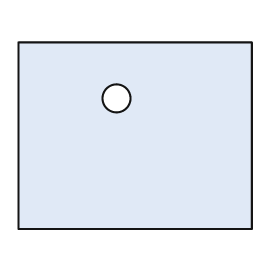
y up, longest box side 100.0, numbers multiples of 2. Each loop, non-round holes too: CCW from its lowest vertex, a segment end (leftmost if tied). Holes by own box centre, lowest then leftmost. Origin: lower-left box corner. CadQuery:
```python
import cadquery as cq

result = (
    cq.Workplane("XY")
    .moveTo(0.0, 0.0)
    .lineTo(100.0, 0.0)
    .lineTo(100.0, 80.0)
    .lineTo(0.0, 80.0)
    .close()
    .moveTo(42.0, 56.0)
    .circle(6.0)
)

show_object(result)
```